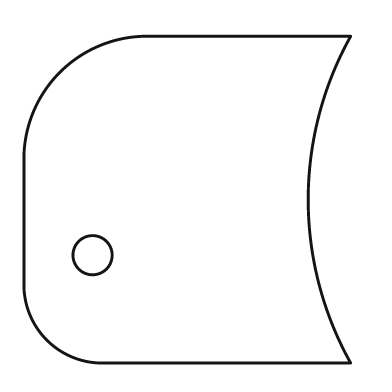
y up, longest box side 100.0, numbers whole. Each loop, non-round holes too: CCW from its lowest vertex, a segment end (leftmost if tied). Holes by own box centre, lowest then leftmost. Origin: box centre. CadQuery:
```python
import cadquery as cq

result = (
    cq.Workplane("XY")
    .moveTo(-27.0, -50.0)
    .lineTo(50.0, -50.0)
    .threePointArc((37.0, 0.0), (50.0, 50.0))
    .lineTo(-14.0, 50.0)
    .threePointArc((-39.0, 39.0), (-50.0, 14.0))
    .lineTo(-50.0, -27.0)
    .threePointArc((-43.0, -43.0), (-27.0, -50.0))
    .close()
    .moveTo(-29.0, -17.0)
    .circle(6.0)
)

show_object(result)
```